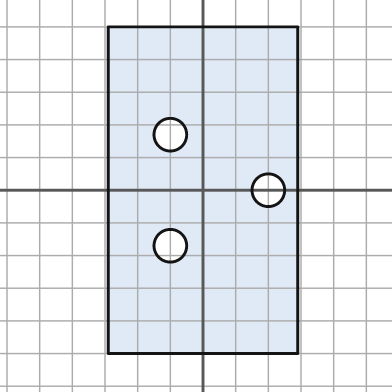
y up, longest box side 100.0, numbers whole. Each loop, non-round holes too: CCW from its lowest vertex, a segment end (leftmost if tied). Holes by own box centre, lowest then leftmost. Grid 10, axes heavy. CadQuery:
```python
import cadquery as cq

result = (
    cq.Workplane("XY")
    .moveTo(-29.0, -50.0)
    .lineTo(29.0, -50.0)
    .lineTo(29.0, 50.0)
    .lineTo(-29.0, 50.0)
    .close()
    .moveTo(-10.0, -17.0)
    .circle(5.0)
    .moveTo(20.0, 0.0)
    .circle(5.0)
    .moveTo(-10.0, 17.0)
    .circle(5.0)
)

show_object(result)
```